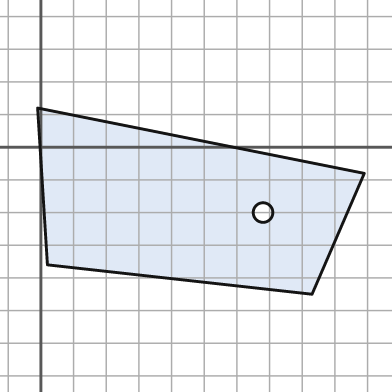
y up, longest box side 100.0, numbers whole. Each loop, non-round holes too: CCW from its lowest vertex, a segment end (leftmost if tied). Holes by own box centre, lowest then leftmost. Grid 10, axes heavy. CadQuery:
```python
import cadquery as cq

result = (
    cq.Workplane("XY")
    .moveTo(83.0, -45.0)
    .lineTo(99.0, -8.0)
    .lineTo(-1.0, 12.0)
    .lineTo(2.0, -36.0)
    .close()
    .moveTo(68.0, -20.0)
    .circle(3.0)
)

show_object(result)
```